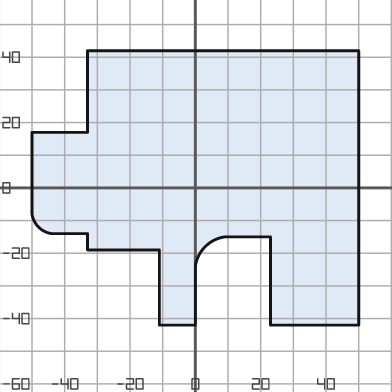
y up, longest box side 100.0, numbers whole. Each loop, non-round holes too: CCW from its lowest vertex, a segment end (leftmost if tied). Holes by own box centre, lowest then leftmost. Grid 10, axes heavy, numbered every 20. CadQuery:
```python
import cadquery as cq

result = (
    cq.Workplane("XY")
    .moveTo(-11.0, -42.0)
    .lineTo(0.0, -42.0)
    .lineTo(0.0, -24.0)
    .threePointArc((3.0, -18.0), (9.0, -15.0))
    .lineTo(23.0, -15.0)
    .lineTo(23.0, -42.0)
    .lineTo(50.0, -42.0)
    .lineTo(50.0, 42.0)
    .lineTo(-33.0, 42.0)
    .lineTo(-33.0, 17.0)
    .lineTo(-50.0, 17.0)
    .lineTo(-50.0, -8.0)
    .threePointArc((-48.0, -12.0), (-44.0, -14.0))
    .lineTo(-33.0, -14.0)
    .lineTo(-33.0, -19.0)
    .lineTo(-11.0, -19.0)
    .close()
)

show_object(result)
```